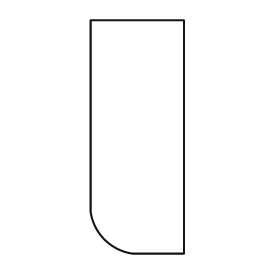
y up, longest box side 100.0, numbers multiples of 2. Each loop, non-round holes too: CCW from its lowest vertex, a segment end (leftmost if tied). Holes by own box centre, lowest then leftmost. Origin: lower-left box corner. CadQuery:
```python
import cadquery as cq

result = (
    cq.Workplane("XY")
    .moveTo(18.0, 0.0)
    .lineTo(40.0, 0.0)
    .lineTo(40.0, 100.0)
    .lineTo(0.0, 100.0)
    .lineTo(0.0, 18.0)
    .threePointArc((6.0, 6.0), (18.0, 0.0))
    .close()
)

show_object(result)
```